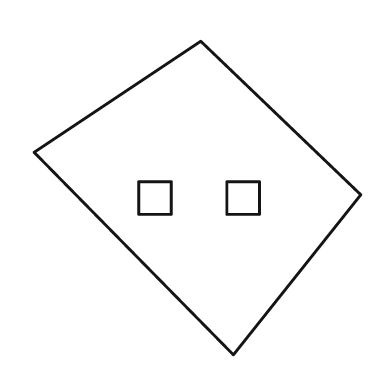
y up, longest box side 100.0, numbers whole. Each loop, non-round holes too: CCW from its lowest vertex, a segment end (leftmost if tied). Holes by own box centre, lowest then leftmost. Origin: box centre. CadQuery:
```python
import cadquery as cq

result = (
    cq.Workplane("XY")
    .moveTo(11.0, -48.0)
    .lineTo(50.0, 1.0)
    .lineTo(1.0, 48.0)
    .lineTo(-50.0, 14.0)
    .close()
    .moveTo(-18.0, -5.0)
    .lineTo(-8.0, -5.0)
    .lineTo(-8.0, 5.0)
    .lineTo(-18.0, 5.0)
    .close()
    .moveTo(9.0, -5.0)
    .lineTo(19.0, -5.0)
    .lineTo(19.0, 5.0)
    .lineTo(9.0, 5.0)
    .close()
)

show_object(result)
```